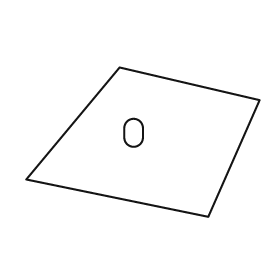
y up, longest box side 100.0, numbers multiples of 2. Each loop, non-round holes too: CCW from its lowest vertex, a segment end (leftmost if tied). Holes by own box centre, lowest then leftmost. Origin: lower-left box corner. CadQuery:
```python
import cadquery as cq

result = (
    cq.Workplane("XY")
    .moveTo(78.0, 0.0)
    .lineTo(100.0, 50.0)
    .lineTo(40.0, 64.0)
    .lineTo(0.0, 16.0)
    .close()
    .moveTo(42.0, 34.0)
    .threePointArc((46.0, 30.0), (50.0, 34.0))
    .lineTo(50.0, 38.0)
    .threePointArc((46.0, 42.0), (42.0, 38.0))
    .close()
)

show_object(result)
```